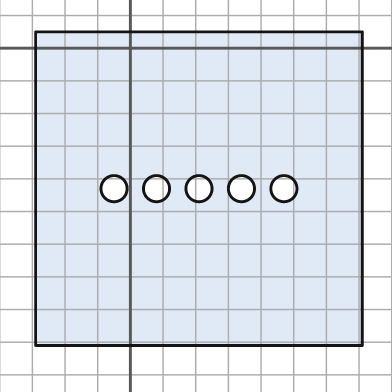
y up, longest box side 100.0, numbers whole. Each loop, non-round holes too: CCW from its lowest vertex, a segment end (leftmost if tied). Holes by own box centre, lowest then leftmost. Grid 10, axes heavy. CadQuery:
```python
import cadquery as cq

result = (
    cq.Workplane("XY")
    .moveTo(-29.0, -91.0)
    .lineTo(71.0, -91.0)
    .lineTo(71.0, 5.0)
    .lineTo(-29.0, 5.0)
    .close()
    .moveTo(-5.0, -43.0)
    .circle(4.0)
    .moveTo(8.0, -43.0)
    .circle(4.0)
    .moveTo(21.0, -43.0)
    .circle(4.0)
    .moveTo(34.0, -43.0)
    .circle(4.0)
    .moveTo(47.0, -43.0)
    .circle(4.0)
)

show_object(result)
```